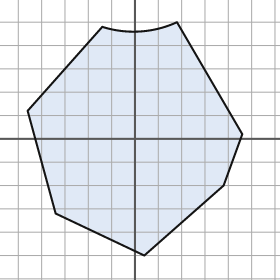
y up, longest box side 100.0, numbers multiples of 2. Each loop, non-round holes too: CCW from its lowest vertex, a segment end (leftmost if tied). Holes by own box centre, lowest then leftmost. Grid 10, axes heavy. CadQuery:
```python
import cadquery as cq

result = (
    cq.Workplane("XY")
    .moveTo(4.0, -50.0)
    .lineTo(38.0, -20.0)
    .lineTo(46.0, 2.0)
    .lineTo(18.0, 50.0)
    .threePointArc((2.0, 46.0), (-14.0, 48.0))
    .lineTo(-46.0, 12.0)
    .lineTo(-34.0, -32.0)
    .close()
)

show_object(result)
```